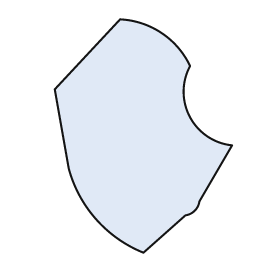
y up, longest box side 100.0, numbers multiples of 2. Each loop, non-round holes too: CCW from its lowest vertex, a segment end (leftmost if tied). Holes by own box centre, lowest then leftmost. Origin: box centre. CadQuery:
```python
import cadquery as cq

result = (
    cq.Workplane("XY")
    .moveTo(0.0, -50.0)
    .lineTo(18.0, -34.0)
    .threePointArc((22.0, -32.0), (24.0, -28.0))
    .lineTo(38.0, -4.0)
    .threePointArc((20.0, 8.0), (20.0, 30.0))
    .threePointArc((8.0, 44.0), (-10.0, 50.0))
    .lineTo(-38.0, 20.0)
    .lineTo(-32.0, -14.0)
    .threePointArc((-20.0, -36.0), (0.0, -50.0))
    .close()
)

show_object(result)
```